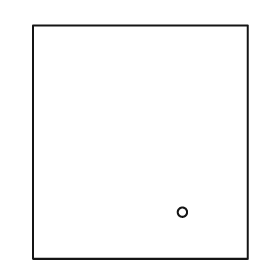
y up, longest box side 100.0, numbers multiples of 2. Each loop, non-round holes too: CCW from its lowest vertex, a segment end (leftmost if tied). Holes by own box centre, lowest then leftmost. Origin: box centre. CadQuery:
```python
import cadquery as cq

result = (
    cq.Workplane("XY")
    .moveTo(-46.0, -50.0)
    .lineTo(46.0, -50.0)
    .lineTo(46.0, 50.0)
    .lineTo(-46.0, 50.0)
    .close()
    .moveTo(18.0, -30.0)
    .circle(2.0)
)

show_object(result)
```